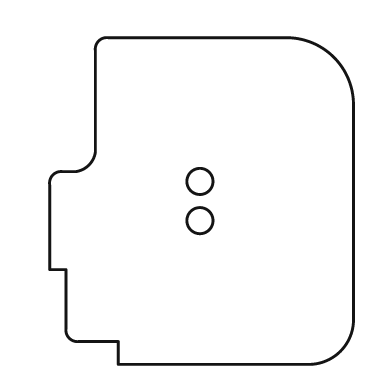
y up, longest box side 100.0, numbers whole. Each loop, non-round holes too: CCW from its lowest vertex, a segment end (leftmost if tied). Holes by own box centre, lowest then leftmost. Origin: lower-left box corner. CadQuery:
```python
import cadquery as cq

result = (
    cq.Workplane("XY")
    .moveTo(21.0, 0.0)
    .lineTo(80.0, 0.0)
    .threePointArc((89.0, 4.0), (93.0, 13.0))
    .lineTo(93.0, 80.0)
    .threePointArc((87.0, 94.0), (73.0, 100.0))
    .lineTo(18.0, 100.0)
    .threePointArc((15.0, 99.0), (14.0, 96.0))
    .lineTo(14.0, 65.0)
    .threePointArc((12.0, 61.0), (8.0, 59.0))
    .lineTo(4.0, 59.0)
    .threePointArc((1.0, 58.0), (0.0, 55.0))
    .lineTo(0.0, 29.0)
    .lineTo(5.0, 29.0)
    .lineTo(5.0, 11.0)
    .threePointArc((6.0, 8.0), (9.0, 7.0))
    .lineTo(21.0, 7.0)
    .close()
    .moveTo(46.0, 44.0)
    .circle(4.0)
    .moveTo(46.0, 56.0)
    .circle(4.0)
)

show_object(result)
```